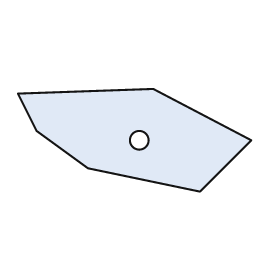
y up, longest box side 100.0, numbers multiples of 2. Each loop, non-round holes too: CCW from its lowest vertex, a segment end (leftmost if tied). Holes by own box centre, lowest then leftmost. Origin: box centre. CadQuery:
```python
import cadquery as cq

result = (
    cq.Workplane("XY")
    .moveTo(28.0, -22.0)
    .lineTo(50.0, 0.0)
    .lineTo(8.0, 22.0)
    .lineTo(-50.0, 20.0)
    .lineTo(-42.0, 4.0)
    .lineTo(-20.0, -12.0)
    .close()
    .moveTo(2.0, 0.0)
    .circle(4.0)
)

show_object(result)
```